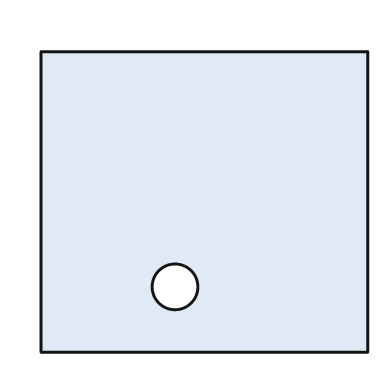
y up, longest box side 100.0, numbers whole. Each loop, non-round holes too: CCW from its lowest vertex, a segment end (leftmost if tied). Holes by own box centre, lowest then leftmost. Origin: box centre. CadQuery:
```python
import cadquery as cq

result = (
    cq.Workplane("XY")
    .moveTo(-50.0, -46.0)
    .lineTo(50.0, -46.0)
    .lineTo(50.0, 46.0)
    .lineTo(-50.0, 46.0)
    .close()
    .moveTo(-9.0, -26.0)
    .circle(7.0)
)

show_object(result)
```